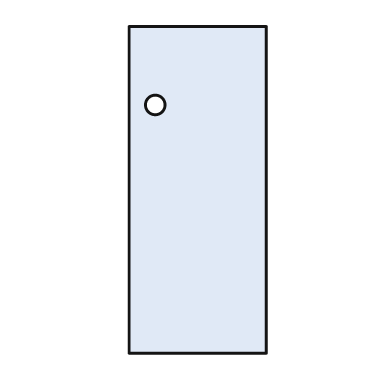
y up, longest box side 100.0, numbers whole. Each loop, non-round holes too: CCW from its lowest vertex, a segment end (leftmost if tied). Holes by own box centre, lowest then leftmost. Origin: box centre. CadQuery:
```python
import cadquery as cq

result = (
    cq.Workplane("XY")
    .moveTo(-21.0, -50.0)
    .lineTo(21.0, -50.0)
    .lineTo(21.0, 50.0)
    .lineTo(-21.0, 50.0)
    .close()
    .moveTo(-13.0, 26.0)
    .circle(3.0)
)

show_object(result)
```